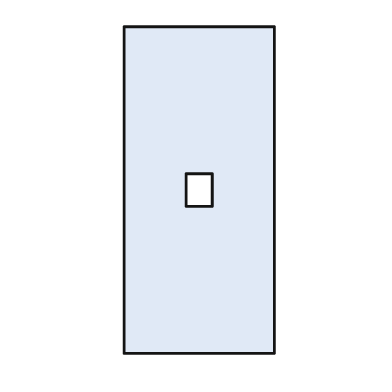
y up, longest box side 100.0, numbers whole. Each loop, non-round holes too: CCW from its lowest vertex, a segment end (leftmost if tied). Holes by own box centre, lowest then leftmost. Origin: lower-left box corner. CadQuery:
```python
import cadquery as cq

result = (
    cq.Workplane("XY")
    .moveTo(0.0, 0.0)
    .lineTo(46.0, 0.0)
    .lineTo(46.0, 100.0)
    .lineTo(0.0, 100.0)
    .close()
    .moveTo(19.0, 45.0)
    .lineTo(27.0, 45.0)
    .lineTo(27.0, 55.0)
    .lineTo(19.0, 55.0)
    .close()
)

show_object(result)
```